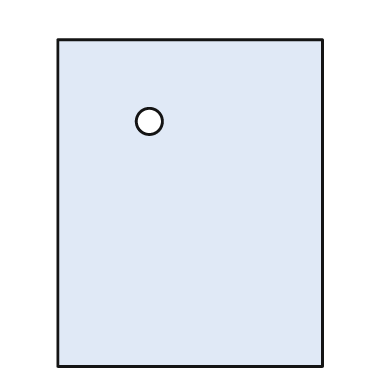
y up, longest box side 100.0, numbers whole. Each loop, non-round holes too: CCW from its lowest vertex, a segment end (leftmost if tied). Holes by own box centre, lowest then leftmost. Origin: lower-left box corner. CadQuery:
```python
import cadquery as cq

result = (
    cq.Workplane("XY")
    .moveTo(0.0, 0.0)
    .lineTo(81.0, 0.0)
    .lineTo(81.0, 100.0)
    .lineTo(0.0, 100.0)
    .close()
    .moveTo(28.0, 75.0)
    .circle(4.0)
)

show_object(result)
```